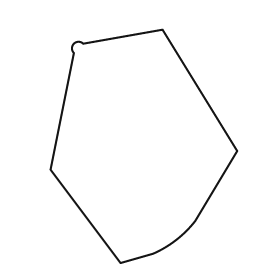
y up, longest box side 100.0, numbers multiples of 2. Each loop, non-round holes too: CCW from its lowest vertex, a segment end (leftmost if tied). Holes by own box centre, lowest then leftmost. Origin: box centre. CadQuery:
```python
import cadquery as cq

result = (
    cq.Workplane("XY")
    .moveTo(-10.0, -50.0)
    .lineTo(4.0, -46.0)
    .threePointArc((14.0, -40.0), (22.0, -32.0))
    .lineTo(40.0, -2.0)
    .lineTo(8.0, 50.0)
    .lineTo(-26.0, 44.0)
    .threePointArc((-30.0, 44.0), (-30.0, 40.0))
    .lineTo(-40.0, -10.0)
    .close()
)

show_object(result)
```